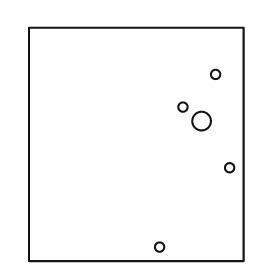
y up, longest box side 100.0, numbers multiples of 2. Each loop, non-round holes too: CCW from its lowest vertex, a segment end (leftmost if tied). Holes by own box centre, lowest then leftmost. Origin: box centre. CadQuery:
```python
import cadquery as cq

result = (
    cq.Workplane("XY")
    .moveTo(-46.0, -50.0)
    .lineTo(46.0, -50.0)
    .lineTo(46.0, 50.0)
    .lineTo(-46.0, 50.0)
    .close()
    .moveTo(10.0, -44.0)
    .circle(2.0)
    .moveTo(40.0, -10.0)
    .circle(2.0)
    .moveTo(28.0, 10.0)
    .circle(4.0)
    .moveTo(20.0, 16.0)
    .circle(2.0)
    .moveTo(34.0, 30.0)
    .circle(2.0)
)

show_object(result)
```